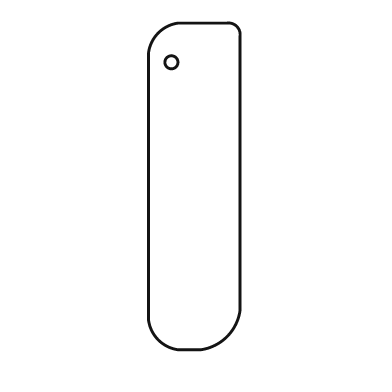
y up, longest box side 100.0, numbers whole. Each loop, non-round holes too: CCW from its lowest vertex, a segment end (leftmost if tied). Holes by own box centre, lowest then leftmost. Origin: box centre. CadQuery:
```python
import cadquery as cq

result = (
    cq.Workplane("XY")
    .moveTo(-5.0, -50.0)
    .lineTo(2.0, -50.0)
    .threePointArc((10.0, -46.0), (14.0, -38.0))
    .lineTo(14.0, 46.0)
    .threePointArc((13.0, 49.0), (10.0, 50.0))
    .lineTo(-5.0, 50.0)
    .threePointArc((-11.0, 47.0), (-14.0, 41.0))
    .lineTo(-14.0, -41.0)
    .threePointArc((-11.0, -47.0), (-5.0, -50.0))
    .close()
    .moveTo(-7.0, 38.0)
    .circle(2.0)
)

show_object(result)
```